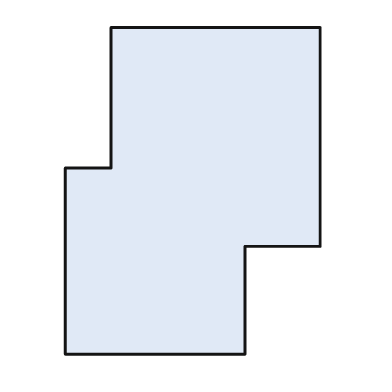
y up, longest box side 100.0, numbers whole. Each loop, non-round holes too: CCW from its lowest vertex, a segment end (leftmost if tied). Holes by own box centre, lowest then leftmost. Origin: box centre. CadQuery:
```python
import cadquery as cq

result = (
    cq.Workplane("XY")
    .moveTo(-39.0, -50.0)
    .lineTo(16.0, -50.0)
    .lineTo(16.0, -17.0)
    .lineTo(39.0, -17.0)
    .lineTo(39.0, 50.0)
    .lineTo(-25.0, 50.0)
    .lineTo(-25.0, 7.0)
    .lineTo(-39.0, 7.0)
    .close()
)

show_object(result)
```